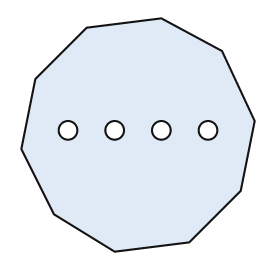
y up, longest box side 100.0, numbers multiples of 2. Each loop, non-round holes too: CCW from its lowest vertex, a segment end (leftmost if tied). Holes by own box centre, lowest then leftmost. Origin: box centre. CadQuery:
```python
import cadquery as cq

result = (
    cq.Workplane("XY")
    .moveTo(-10.0, -50.0)
    .lineTo(22.0, -46.0)
    .lineTo(44.0, -24.0)
    .lineTo(50.0, 6.0)
    .lineTo(36.0, 36.0)
    .lineTo(10.0, 50.0)
    .lineTo(-22.0, 46.0)
    .lineTo(-44.0, 24.0)
    .lineTo(-50.0, -6.0)
    .lineTo(-36.0, -34.0)
    .close()
    .moveTo(-30.0, 2.0)
    .circle(4.0)
    .moveTo(-10.0, 2.0)
    .circle(4.0)
    .moveTo(10.0, 2.0)
    .circle(4.0)
    .moveTo(30.0, 2.0)
    .circle(4.0)
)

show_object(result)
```